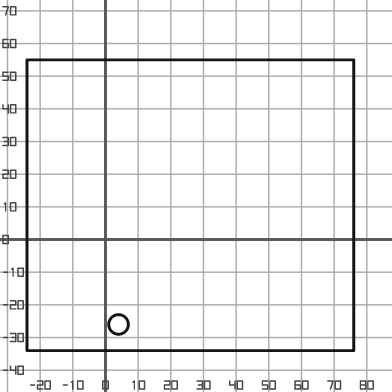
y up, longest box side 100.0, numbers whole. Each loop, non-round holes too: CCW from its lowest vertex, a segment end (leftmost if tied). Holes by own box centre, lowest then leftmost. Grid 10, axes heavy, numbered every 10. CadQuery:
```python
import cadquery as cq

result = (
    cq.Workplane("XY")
    .moveTo(-24.0, -34.0)
    .lineTo(76.0, -34.0)
    .lineTo(76.0, 55.0)
    .lineTo(-24.0, 55.0)
    .close()
    .moveTo(4.0, -26.0)
    .circle(3.0)
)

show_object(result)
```